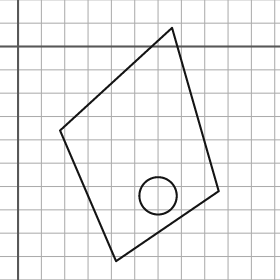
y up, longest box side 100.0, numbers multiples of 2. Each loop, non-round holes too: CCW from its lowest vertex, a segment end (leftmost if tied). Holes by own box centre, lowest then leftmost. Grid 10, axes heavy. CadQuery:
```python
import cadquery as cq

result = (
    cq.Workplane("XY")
    .moveTo(42.0, -92.0)
    .lineTo(86.0, -62.0)
    .lineTo(66.0, 8.0)
    .lineTo(18.0, -36.0)
    .close()
    .moveTo(60.0, -64.0)
    .circle(8.0)
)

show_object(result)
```